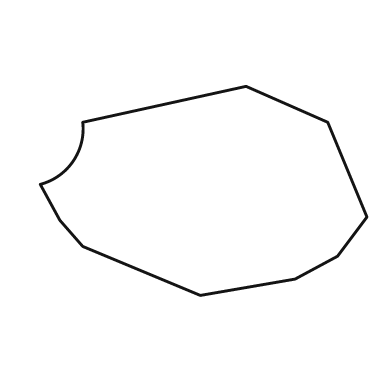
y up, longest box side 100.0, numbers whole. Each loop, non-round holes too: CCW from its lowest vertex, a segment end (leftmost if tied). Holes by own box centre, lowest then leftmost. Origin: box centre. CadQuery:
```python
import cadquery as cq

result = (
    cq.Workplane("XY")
    .moveTo(-1.0, -32.0)
    .lineTo(28.0, -27.0)
    .lineTo(41.0, -20.0)
    .lineTo(50.0, -8.0)
    .lineTo(38.0, 21.0)
    .lineTo(13.0, 32.0)
    .lineTo(-37.0, 21.0)
    .threePointArc((-40.0, 9.0), (-50.0, 2.0))
    .lineTo(-44.0, -9.0)
    .lineTo(-37.0, -17.0)
    .close()
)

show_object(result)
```